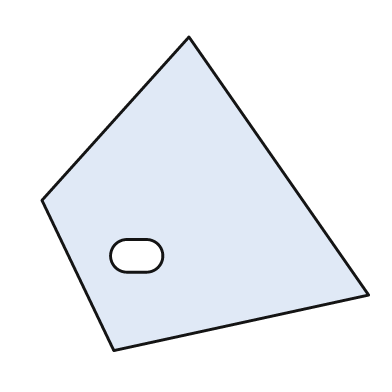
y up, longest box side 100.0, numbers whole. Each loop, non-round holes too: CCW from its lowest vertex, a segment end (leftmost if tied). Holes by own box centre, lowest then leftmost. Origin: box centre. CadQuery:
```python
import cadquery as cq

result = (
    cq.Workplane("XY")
    .moveTo(-28.0, -48.0)
    .lineTo(50.0, -31.0)
    .lineTo(-5.0, 48.0)
    .lineTo(-50.0, -2.0)
    .close()
    .moveTo(-24.0, -24.0)
    .lineTo(-18.0, -24.0)
    .threePointArc((-13.0, -19.0), (-18.0, -14.0))
    .lineTo(-24.0, -14.0)
    .threePointArc((-29.0, -19.0), (-24.0, -24.0))
    .close()
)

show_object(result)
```